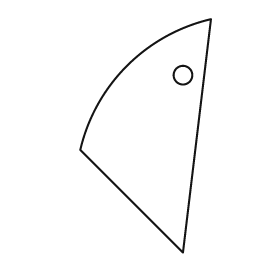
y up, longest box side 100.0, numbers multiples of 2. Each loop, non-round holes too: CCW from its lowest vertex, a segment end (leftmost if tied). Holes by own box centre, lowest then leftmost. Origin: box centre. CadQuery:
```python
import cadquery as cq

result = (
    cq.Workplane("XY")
    .moveTo(16.0, -50.0)
    .lineTo(28.0, 50.0)
    .threePointArc((-8.0, 30.0), (-28.0, -6.0))
    .close()
    .moveTo(16.0, 26.0)
    .circle(4.0)
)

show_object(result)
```